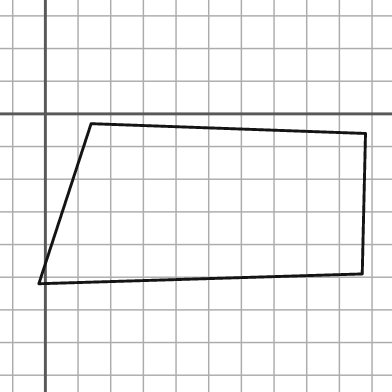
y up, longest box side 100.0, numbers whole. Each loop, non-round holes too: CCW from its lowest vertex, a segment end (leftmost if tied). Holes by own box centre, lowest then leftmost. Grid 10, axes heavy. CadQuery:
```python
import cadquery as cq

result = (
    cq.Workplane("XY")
    .moveTo(-2.0, -52.0)
    .lineTo(97.0, -49.0)
    .lineTo(98.0, -6.0)
    .lineTo(14.0, -3.0)
    .close()
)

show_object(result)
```